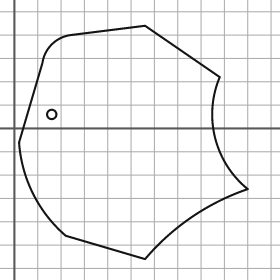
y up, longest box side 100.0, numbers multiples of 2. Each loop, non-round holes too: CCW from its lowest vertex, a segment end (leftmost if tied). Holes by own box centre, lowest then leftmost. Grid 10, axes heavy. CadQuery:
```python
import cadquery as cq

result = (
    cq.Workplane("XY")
    .moveTo(56.0, -56.0)
    .threePointArc((76.0, -38.0), (100.0, -26.0))
    .threePointArc((86.0, -4.0), (88.0, 22.0))
    .lineTo(56.0, 44.0)
    .lineTo(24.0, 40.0)
    .threePointArc((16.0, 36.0), (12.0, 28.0))
    .lineTo(2.0, -6.0)
    .threePointArc((8.0, -28.0), (22.0, -46.0))
    .close()
    .moveTo(16.0, 6.0)
    .circle(2.0)
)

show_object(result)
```